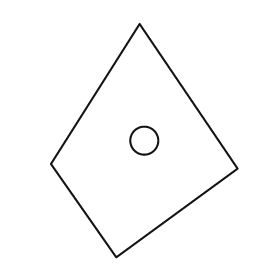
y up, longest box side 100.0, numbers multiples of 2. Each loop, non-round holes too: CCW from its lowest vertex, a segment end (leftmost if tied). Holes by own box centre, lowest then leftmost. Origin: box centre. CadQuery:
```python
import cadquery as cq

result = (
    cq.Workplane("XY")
    .moveTo(-12.0, -50.0)
    .lineTo(40.0, -12.0)
    .lineTo(-2.0, 50.0)
    .lineTo(-40.0, -10.0)
    .close()
    .moveTo(0.0, 0.0)
    .circle(6.0)
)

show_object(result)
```